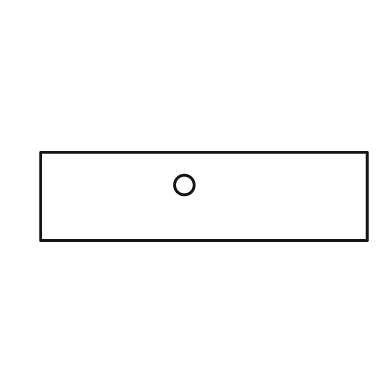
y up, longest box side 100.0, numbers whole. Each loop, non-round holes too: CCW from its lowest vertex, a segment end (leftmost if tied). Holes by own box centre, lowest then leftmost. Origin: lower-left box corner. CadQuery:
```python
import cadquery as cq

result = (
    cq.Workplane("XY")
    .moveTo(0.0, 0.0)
    .lineTo(100.0, 0.0)
    .lineTo(100.0, 27.0)
    .lineTo(0.0, 27.0)
    .close()
    .moveTo(44.0, 17.0)
    .circle(3.0)
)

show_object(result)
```